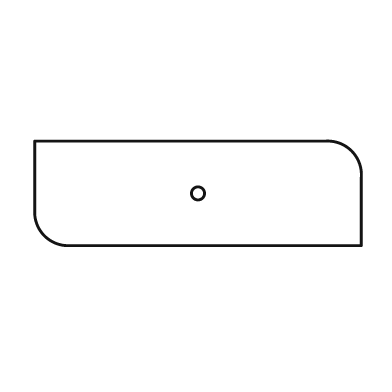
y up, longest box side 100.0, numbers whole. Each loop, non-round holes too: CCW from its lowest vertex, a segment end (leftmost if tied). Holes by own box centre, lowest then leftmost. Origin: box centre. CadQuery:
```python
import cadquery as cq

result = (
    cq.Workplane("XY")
    .moveTo(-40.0, -16.0)
    .lineTo(50.0, -16.0)
    .lineTo(50.0, 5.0)
    .threePointArc((47.0, 13.0), (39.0, 16.0))
    .lineTo(-50.0, 16.0)
    .lineTo(-50.0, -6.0)
    .threePointArc((-47.0, -13.0), (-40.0, -16.0))
    .close()
    .moveTo(0.0, 0.0)
    .circle(2.0)
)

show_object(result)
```